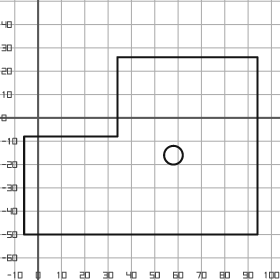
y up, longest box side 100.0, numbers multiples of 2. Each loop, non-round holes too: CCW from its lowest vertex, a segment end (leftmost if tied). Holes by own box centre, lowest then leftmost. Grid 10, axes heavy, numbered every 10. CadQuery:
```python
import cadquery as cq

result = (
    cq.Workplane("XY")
    .moveTo(-6.0, -50.0)
    .lineTo(94.0, -50.0)
    .lineTo(94.0, 26.0)
    .lineTo(34.0, 26.0)
    .lineTo(34.0, -8.0)
    .lineTo(-6.0, -8.0)
    .close()
    .moveTo(58.0, -16.0)
    .circle(4.0)
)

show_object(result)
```